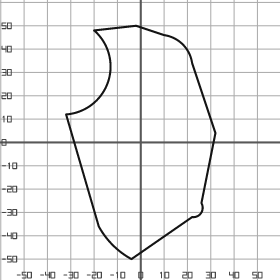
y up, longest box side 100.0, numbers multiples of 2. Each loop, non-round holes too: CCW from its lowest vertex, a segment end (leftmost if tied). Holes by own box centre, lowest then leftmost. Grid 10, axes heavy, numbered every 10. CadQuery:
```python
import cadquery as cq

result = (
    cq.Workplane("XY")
    .moveTo(-4.0, -50.0)
    .lineTo(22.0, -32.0)
    .threePointArc((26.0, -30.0), (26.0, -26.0))
    .lineTo(32.0, 4.0)
    .lineTo(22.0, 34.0)
    .threePointArc((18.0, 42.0), (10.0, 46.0))
    .lineTo(-2.0, 50.0)
    .lineTo(-20.0, 48.0)
    .threePointArc((-14.0, 26.0), (-32.0, 12.0))
    .lineTo(-18.0, -36.0)
    .threePointArc((-12.0, -44.0), (-4.0, -50.0))
    .close()
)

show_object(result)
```